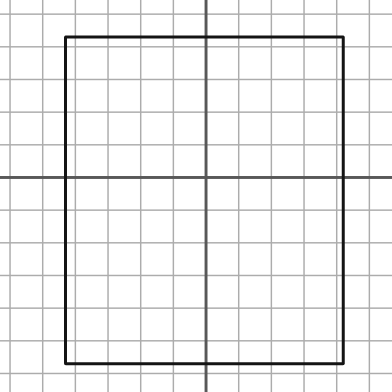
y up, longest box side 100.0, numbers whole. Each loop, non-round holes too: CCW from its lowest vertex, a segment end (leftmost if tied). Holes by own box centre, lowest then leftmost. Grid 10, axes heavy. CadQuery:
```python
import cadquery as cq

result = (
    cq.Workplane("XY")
    .moveTo(-43.0, -57.0)
    .lineTo(42.0, -57.0)
    .lineTo(42.0, 43.0)
    .lineTo(-43.0, 43.0)
    .close()
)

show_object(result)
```